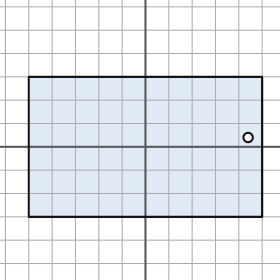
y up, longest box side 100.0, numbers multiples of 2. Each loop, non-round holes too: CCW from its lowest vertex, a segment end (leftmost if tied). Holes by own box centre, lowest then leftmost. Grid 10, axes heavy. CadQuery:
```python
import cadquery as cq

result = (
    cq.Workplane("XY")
    .moveTo(-50.0, -30.0)
    .lineTo(50.0, -30.0)
    .lineTo(50.0, 30.0)
    .lineTo(-50.0, 30.0)
    .close()
    .moveTo(44.0, 4.0)
    .circle(2.0)
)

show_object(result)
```